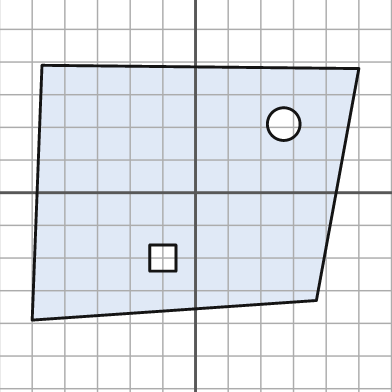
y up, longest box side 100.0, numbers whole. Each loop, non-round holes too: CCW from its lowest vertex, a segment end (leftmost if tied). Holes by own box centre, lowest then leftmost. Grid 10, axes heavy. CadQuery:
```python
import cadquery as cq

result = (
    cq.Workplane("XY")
    .moveTo(-50.0, -39.0)
    .lineTo(37.0, -33.0)
    .lineTo(50.0, 38.0)
    .lineTo(-47.0, 39.0)
    .close()
    .moveTo(-14.0, -24.0)
    .lineTo(-6.0, -24.0)
    .lineTo(-6.0, -16.0)
    .lineTo(-14.0, -16.0)
    .close()
    .moveTo(27.0, 21.0)
    .circle(5.0)
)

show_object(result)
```